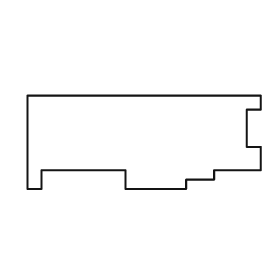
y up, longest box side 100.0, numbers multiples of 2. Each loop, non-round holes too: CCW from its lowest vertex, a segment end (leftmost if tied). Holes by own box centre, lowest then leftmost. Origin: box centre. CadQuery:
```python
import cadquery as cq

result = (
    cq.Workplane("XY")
    .moveTo(-50.0, -20.0)
    .lineTo(-44.0, -20.0)
    .lineTo(-44.0, -12.0)
    .lineTo(-8.0, -12.0)
    .lineTo(-8.0, -20.0)
    .lineTo(18.0, -20.0)
    .lineTo(18.0, -16.0)
    .lineTo(30.0, -16.0)
    .lineTo(30.0, -12.0)
    .lineTo(50.0, -12.0)
    .lineTo(50.0, -2.0)
    .lineTo(44.0, -2.0)
    .lineTo(44.0, 14.0)
    .lineTo(50.0, 14.0)
    .lineTo(50.0, 20.0)
    .lineTo(-50.0, 20.0)
    .close()
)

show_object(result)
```